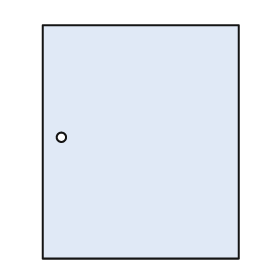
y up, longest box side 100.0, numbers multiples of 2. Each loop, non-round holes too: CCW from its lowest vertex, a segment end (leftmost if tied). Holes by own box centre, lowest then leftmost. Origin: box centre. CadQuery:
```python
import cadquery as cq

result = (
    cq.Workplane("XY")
    .moveTo(-42.0, -50.0)
    .lineTo(42.0, -50.0)
    .lineTo(42.0, 50.0)
    .lineTo(-42.0, 50.0)
    .close()
    .moveTo(-34.0, 2.0)
    .circle(2.0)
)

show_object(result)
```